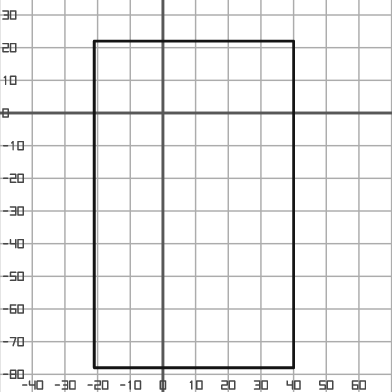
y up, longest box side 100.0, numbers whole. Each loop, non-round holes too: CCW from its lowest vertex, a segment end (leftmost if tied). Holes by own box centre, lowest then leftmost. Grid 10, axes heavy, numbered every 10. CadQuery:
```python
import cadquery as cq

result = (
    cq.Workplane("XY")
    .moveTo(-21.0, -78.0)
    .lineTo(40.0, -78.0)
    .lineTo(40.0, 22.0)
    .lineTo(-21.0, 22.0)
    .close()
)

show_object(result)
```